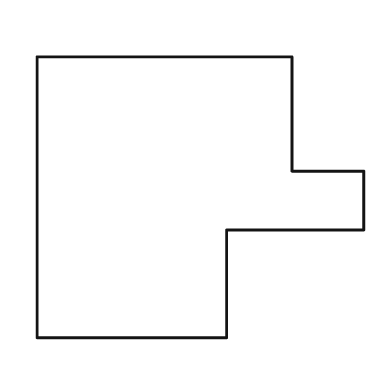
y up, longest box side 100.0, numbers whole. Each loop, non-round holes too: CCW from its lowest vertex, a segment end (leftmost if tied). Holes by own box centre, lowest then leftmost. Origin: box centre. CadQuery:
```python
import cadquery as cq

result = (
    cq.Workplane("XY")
    .moveTo(-50.0, -43.0)
    .lineTo(8.0, -43.0)
    .lineTo(8.0, -10.0)
    .lineTo(50.0, -10.0)
    .lineTo(50.0, 8.0)
    .lineTo(28.0, 8.0)
    .lineTo(28.0, 43.0)
    .lineTo(-50.0, 43.0)
    .close()
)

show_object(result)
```